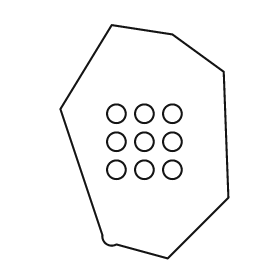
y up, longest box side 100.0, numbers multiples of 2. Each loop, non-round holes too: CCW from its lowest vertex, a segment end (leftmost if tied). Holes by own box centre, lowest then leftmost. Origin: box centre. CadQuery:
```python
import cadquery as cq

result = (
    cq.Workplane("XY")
    .moveTo(10.0, -50.0)
    .lineTo(36.0, -24.0)
    .lineTo(34.0, 30.0)
    .lineTo(12.0, 46.0)
    .lineTo(-14.0, 50.0)
    .lineTo(-36.0, 14.0)
    .lineTo(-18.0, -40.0)
    .threePointArc((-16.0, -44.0), (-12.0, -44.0))
    .close()
    .moveTo(-12.0, -12.0)
    .circle(4.0)
    .moveTo(0.0, -12.0)
    .circle(4.0)
    .moveTo(12.0, -12.0)
    .circle(4.0)
    .moveTo(-12.0, 0.0)
    .circle(4.0)
    .moveTo(0.0, 0.0)
    .circle(4.0)
    .moveTo(12.0, 0.0)
    .circle(4.0)
    .moveTo(-12.0, 12.0)
    .circle(4.0)
    .moveTo(0.0, 12.0)
    .circle(4.0)
    .moveTo(12.0, 12.0)
    .circle(4.0)
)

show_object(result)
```